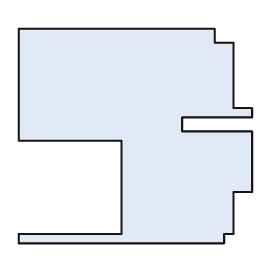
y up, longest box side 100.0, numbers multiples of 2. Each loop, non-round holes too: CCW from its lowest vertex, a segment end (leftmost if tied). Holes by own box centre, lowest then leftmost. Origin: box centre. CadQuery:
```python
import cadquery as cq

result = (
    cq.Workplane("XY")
    .moveTo(-50.0, -46.0)
    .lineTo(38.0, -46.0)
    .lineTo(38.0, -42.0)
    .lineTo(42.0, -42.0)
    .lineTo(42.0, -24.0)
    .lineTo(50.0, -24.0)
    .lineTo(50.0, 2.0)
    .lineTo(20.0, 2.0)
    .lineTo(20.0, 8.0)
    .lineTo(50.0, 8.0)
    .lineTo(50.0, 12.0)
    .lineTo(42.0, 12.0)
    .lineTo(42.0, 40.0)
    .lineTo(34.0, 40.0)
    .lineTo(34.0, 46.0)
    .lineTo(-50.0, 46.0)
    .lineTo(-50.0, -2.0)
    .lineTo(-6.0, -2.0)
    .lineTo(-6.0, -42.0)
    .lineTo(-50.0, -42.0)
    .close()
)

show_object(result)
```